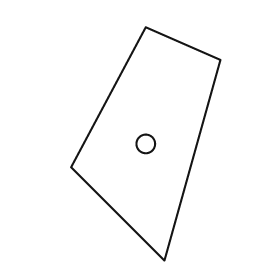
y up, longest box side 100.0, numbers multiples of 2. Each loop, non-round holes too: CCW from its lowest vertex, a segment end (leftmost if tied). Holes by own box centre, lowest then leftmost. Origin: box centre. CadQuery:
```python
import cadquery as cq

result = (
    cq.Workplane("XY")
    .moveTo(8.0, -50.0)
    .lineTo(32.0, 36.0)
    .lineTo(0.0, 50.0)
    .lineTo(-32.0, -10.0)
    .close()
    .moveTo(0.0, 0.0)
    .circle(4.0)
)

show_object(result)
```